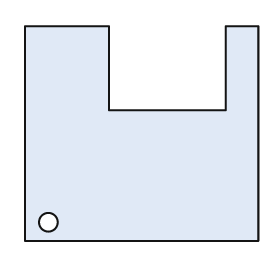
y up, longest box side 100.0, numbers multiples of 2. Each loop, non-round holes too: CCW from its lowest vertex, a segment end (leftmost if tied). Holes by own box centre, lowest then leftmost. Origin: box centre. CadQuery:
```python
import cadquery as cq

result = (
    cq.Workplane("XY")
    .moveTo(-50.0, -46.0)
    .lineTo(50.0, -46.0)
    .lineTo(50.0, 46.0)
    .lineTo(36.0, 46.0)
    .lineTo(36.0, 10.0)
    .lineTo(-14.0, 10.0)
    .lineTo(-14.0, 46.0)
    .lineTo(-50.0, 46.0)
    .close()
    .moveTo(-40.0, -38.0)
    .circle(4.0)
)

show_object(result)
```